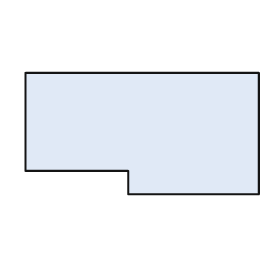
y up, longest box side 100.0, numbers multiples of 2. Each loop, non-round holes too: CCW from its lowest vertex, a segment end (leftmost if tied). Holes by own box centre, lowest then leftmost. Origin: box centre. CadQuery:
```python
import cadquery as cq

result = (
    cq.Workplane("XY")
    .moveTo(-6.0, -26.0)
    .lineTo(50.0, -26.0)
    .lineTo(50.0, 26.0)
    .lineTo(-50.0, 26.0)
    .lineTo(-50.0, -16.0)
    .lineTo(-6.0, -16.0)
    .close()
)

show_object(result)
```